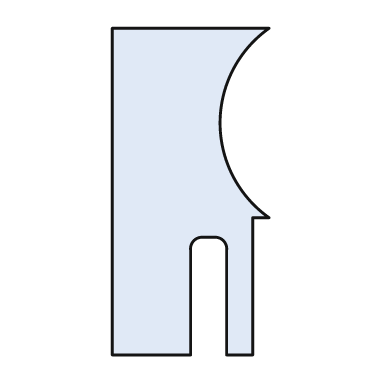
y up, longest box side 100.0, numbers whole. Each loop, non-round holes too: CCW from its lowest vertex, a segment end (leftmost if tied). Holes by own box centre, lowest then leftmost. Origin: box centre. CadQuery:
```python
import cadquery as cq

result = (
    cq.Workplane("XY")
    .moveTo(-24.0, -50.0)
    .lineTo(0.0, -50.0)
    .lineTo(0.0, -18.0)
    .threePointArc((1.0, -15.0), (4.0, -14.0))
    .lineTo(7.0, -14.0)
    .threePointArc((10.0, -15.0), (11.0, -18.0))
    .lineTo(11.0, -50.0)
    .lineTo(19.0, -50.0)
    .lineTo(19.0, -8.0)
    .lineTo(24.0, -8.0)
    .threePointArc((9.0, 21.0), (24.0, 50.0))
    .lineTo(-24.0, 50.0)
    .close()
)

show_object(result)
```